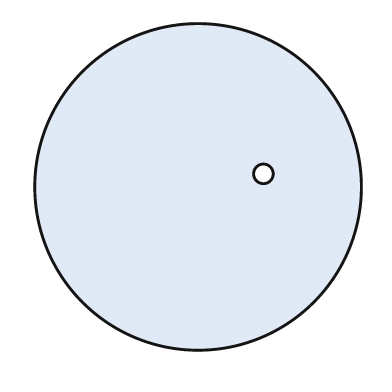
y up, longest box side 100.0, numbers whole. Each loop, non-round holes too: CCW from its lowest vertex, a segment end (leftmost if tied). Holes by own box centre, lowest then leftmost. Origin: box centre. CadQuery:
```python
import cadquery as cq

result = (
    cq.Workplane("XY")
    .moveTo(0.0, 0.0)
    .circle(50.0)
    .moveTo(20.0, 4.0)
    .circle(3.0)
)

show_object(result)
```